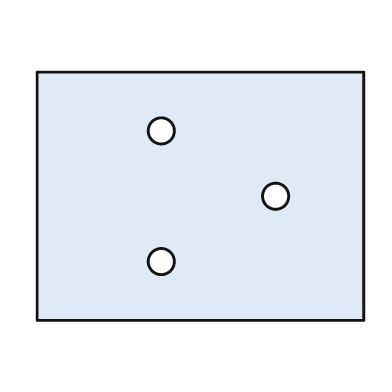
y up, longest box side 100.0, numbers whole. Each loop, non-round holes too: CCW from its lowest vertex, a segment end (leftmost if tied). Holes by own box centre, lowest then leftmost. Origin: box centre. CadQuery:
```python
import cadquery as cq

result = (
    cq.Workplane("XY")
    .moveTo(-50.0, -38.0)
    .lineTo(50.0, -38.0)
    .lineTo(50.0, 38.0)
    .lineTo(-50.0, 38.0)
    .close()
    .moveTo(-12.0, -20.0)
    .circle(4.0)
    .moveTo(23.0, 0.0)
    .circle(4.0)
    .moveTo(-12.0, 20.0)
    .circle(4.0)
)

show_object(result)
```